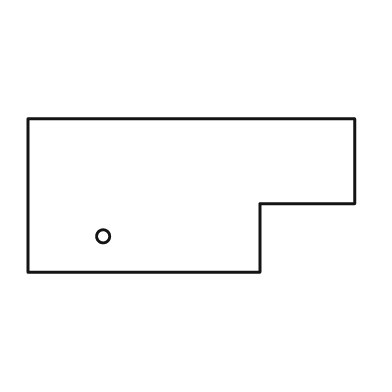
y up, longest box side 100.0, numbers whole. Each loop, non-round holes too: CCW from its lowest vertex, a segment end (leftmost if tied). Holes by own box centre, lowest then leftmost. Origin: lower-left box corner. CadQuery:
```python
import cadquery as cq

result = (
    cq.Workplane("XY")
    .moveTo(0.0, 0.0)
    .lineTo(71.0, 0.0)
    .lineTo(71.0, 21.0)
    .lineTo(100.0, 21.0)
    .lineTo(100.0, 47.0)
    .lineTo(0.0, 47.0)
    .close()
    .moveTo(23.0, 11.0)
    .circle(2.0)
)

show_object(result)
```